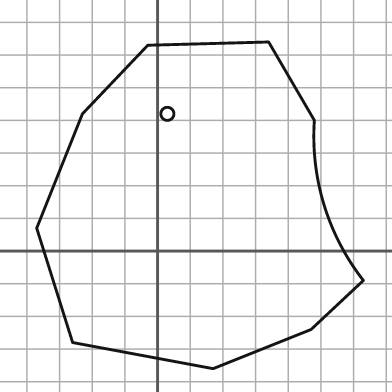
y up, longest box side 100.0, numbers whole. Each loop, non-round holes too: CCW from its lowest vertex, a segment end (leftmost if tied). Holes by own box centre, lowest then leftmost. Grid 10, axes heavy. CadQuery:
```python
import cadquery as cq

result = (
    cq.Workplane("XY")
    .moveTo(17.0, -36.0)
    .lineTo(47.0, -24.0)
    .lineTo(63.0, -9.0)
    .threePointArc((51.0, 14.0), (48.0, 40.0))
    .lineTo(34.0, 64.0)
    .lineTo(-3.0, 63.0)
    .lineTo(-23.0, 42.0)
    .lineTo(-37.0, 7.0)
    .lineTo(-26.0, -28.0)
    .close()
    .moveTo(3.0, 42.0)
    .circle(2.0)
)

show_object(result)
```